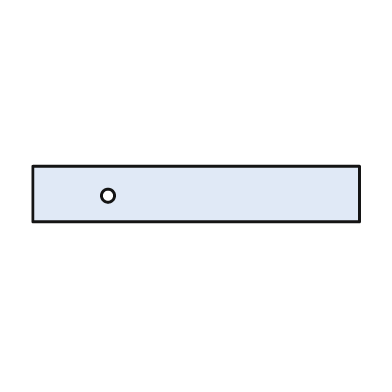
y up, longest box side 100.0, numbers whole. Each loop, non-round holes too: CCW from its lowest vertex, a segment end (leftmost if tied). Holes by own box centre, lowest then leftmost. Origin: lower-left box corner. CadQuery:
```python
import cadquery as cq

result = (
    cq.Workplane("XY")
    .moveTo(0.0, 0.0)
    .lineTo(100.0, 0.0)
    .lineTo(100.0, 17.0)
    .lineTo(0.0, 17.0)
    .close()
    .moveTo(23.0, 8.0)
    .circle(2.0)
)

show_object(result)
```